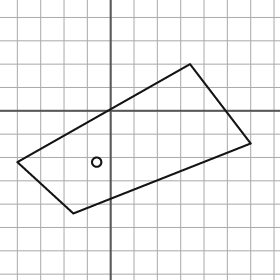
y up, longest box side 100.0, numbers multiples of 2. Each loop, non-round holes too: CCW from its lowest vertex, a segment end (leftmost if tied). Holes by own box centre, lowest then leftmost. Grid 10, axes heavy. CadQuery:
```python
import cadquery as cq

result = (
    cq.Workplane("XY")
    .moveTo(-16.0, -44.0)
    .lineTo(60.0, -14.0)
    .lineTo(34.0, 20.0)
    .lineTo(-40.0, -22.0)
    .close()
    .moveTo(-6.0, -22.0)
    .circle(2.0)
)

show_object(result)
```